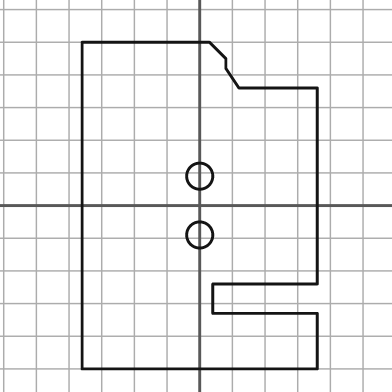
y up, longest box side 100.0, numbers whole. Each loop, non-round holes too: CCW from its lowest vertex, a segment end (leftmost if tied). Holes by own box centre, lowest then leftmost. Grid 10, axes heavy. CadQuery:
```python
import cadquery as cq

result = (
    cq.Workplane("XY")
    .moveTo(-36.0, -50.0)
    .lineTo(36.0, -50.0)
    .lineTo(36.0, -33.0)
    .lineTo(4.0, -33.0)
    .lineTo(4.0, -24.0)
    .lineTo(36.0, -24.0)
    .lineTo(36.0, 36.0)
    .lineTo(12.0, 36.0)
    .lineTo(8.0, 42.0)
    .lineTo(8.0, 45.0)
    .lineTo(3.0, 50.0)
    .lineTo(-36.0, 50.0)
    .close()
    .moveTo(0.0, -9.0)
    .circle(4.0)
    .moveTo(0.0, 9.0)
    .circle(4.0)
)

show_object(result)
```